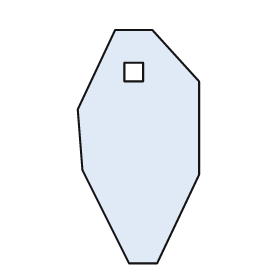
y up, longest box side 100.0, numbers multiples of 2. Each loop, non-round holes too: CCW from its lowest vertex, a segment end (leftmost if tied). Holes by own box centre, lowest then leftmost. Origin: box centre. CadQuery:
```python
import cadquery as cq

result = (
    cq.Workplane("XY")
    .moveTo(-4.0, -50.0)
    .lineTo(8.0, -50.0)
    .lineTo(26.0, -12.0)
    .lineTo(26.0, 28.0)
    .lineTo(6.0, 50.0)
    .lineTo(-10.0, 50.0)
    .lineTo(-26.0, 16.0)
    .lineTo(-24.0, -10.0)
    .close()
    .moveTo(-6.0, 28.0)
    .lineTo(2.0, 28.0)
    .lineTo(2.0, 36.0)
    .lineTo(-6.0, 36.0)
    .close()
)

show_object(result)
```